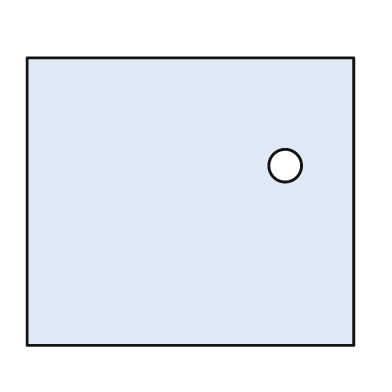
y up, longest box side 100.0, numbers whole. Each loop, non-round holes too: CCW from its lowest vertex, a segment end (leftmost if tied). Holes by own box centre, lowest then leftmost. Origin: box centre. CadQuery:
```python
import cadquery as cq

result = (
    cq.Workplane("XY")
    .moveTo(-50.0, -44.0)
    .lineTo(50.0, -44.0)
    .lineTo(50.0, 44.0)
    .lineTo(-50.0, 44.0)
    .close()
    .moveTo(29.0, 11.0)
    .circle(5.0)
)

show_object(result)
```